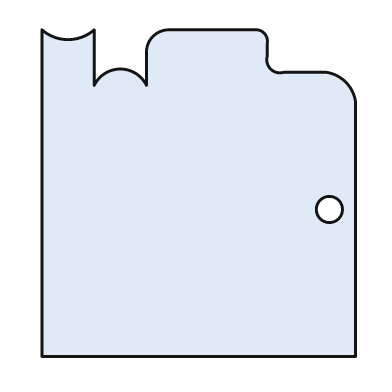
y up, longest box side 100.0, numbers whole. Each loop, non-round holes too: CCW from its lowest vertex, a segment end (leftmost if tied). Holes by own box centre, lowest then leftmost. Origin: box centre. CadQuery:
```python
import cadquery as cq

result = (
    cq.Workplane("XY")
    .moveTo(-48.0, -50.0)
    .lineTo(48.0, -50.0)
    .lineTo(48.0, 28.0)
    .threePointArc((45.0, 34.0), (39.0, 37.0))
    .lineTo(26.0, 37.0)
    .threePointArc((22.0, 38.0), (21.0, 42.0))
    .lineTo(21.0, 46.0)
    .threePointArc((20.0, 49.0), (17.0, 50.0))
    .lineTo(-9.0, 50.0)
    .threePointArc((-14.0, 48.0), (-16.0, 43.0))
    .lineTo(-16.0, 33.0)
    .threePointArc((-24.0, 38.0), (-32.0, 33.0))
    .lineTo(-32.0, 50.0)
    .threePointArc((-40.0, 47.0), (-48.0, 50.0))
    .close()
    .moveTo(40.0, -5.0)
    .circle(4.0)
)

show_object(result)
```